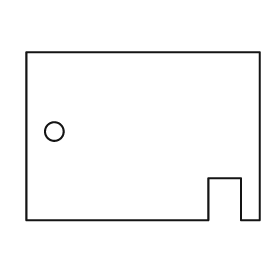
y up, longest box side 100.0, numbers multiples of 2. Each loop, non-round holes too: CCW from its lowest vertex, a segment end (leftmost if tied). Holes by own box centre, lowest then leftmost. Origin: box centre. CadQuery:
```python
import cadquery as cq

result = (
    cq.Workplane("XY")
    .moveTo(-50.0, -36.0)
    .lineTo(28.0, -36.0)
    .lineTo(28.0, -18.0)
    .lineTo(42.0, -18.0)
    .lineTo(42.0, -36.0)
    .lineTo(50.0, -36.0)
    .lineTo(50.0, 36.0)
    .lineTo(-50.0, 36.0)
    .close()
    .moveTo(-38.0, 2.0)
    .circle(4.0)
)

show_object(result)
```